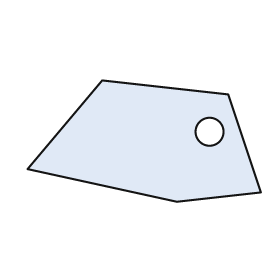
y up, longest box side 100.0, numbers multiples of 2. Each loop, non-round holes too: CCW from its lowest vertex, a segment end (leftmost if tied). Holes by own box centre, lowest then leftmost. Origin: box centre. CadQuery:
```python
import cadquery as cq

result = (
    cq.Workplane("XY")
    .moveTo(14.0, -26.0)
    .lineTo(50.0, -22.0)
    .lineTo(36.0, 20.0)
    .lineTo(-18.0, 26.0)
    .lineTo(-50.0, -12.0)
    .close()
    .moveTo(28.0, 4.0)
    .circle(6.0)
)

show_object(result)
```